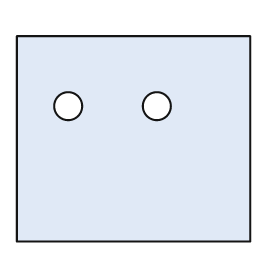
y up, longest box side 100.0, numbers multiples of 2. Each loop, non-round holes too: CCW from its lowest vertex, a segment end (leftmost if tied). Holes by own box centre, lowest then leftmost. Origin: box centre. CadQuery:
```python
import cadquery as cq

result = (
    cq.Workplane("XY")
    .moveTo(-50.0, -44.0)
    .lineTo(50.0, -44.0)
    .lineTo(50.0, 44.0)
    .lineTo(-50.0, 44.0)
    .close()
    .moveTo(-28.0, 14.0)
    .circle(6.0)
    .moveTo(10.0, 14.0)
    .circle(6.0)
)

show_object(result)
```